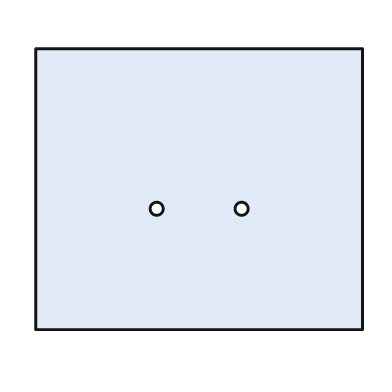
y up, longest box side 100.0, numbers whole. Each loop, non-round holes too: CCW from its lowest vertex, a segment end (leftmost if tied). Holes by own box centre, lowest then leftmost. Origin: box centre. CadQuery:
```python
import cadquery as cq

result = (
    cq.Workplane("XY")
    .moveTo(-50.0, -43.0)
    .lineTo(50.0, -43.0)
    .lineTo(50.0, 43.0)
    .lineTo(-50.0, 43.0)
    .close()
    .moveTo(-13.0, -6.0)
    .circle(2.0)
    .moveTo(13.0, -6.0)
    .circle(2.0)
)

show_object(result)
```